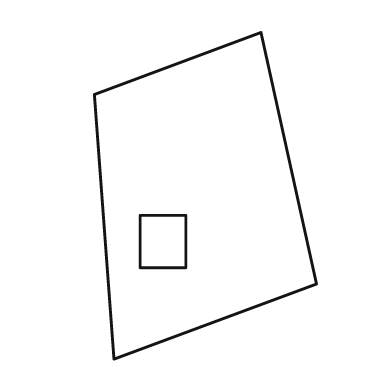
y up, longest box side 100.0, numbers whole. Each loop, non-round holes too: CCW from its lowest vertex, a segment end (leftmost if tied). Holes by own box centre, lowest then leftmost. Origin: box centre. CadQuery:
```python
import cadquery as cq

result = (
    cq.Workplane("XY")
    .moveTo(-28.0, -50.0)
    .lineTo(34.0, -27.0)
    .lineTo(17.0, 50.0)
    .lineTo(-34.0, 31.0)
    .close()
    .moveTo(-20.0, -22.0)
    .lineTo(-6.0, -22.0)
    .lineTo(-6.0, -6.0)
    .lineTo(-20.0, -6.0)
    .close()
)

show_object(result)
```